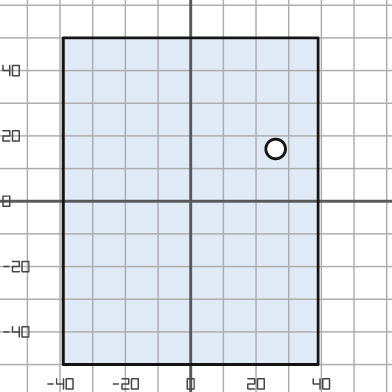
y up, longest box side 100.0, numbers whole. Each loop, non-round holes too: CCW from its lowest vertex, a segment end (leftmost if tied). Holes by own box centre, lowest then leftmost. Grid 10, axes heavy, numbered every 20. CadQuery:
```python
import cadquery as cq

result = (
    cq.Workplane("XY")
    .moveTo(-39.0, -50.0)
    .lineTo(39.0, -50.0)
    .lineTo(39.0, 50.0)
    .lineTo(-39.0, 50.0)
    .close()
    .moveTo(26.0, 16.0)
    .circle(3.0)
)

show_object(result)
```